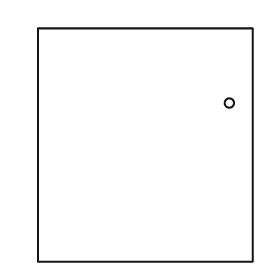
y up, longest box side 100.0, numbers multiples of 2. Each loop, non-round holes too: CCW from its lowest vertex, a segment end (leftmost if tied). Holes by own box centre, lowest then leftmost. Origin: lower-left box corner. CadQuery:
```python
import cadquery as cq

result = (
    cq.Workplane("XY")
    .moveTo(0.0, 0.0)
    .lineTo(92.0, 0.0)
    .lineTo(92.0, 100.0)
    .lineTo(0.0, 100.0)
    .close()
    .moveTo(82.0, 68.0)
    .circle(2.0)
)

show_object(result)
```